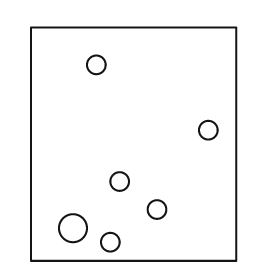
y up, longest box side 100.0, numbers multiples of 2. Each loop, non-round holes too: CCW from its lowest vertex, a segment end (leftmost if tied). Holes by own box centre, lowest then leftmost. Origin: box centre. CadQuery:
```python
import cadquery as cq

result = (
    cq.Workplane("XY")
    .moveTo(-44.0, -50.0)
    .lineTo(44.0, -50.0)
    .lineTo(44.0, 50.0)
    .lineTo(-44.0, 50.0)
    .close()
    .moveTo(-10.0, -42.0)
    .circle(4.0)
    .moveTo(-26.0, -36.0)
    .circle(6.0)
    .moveTo(10.0, -28.0)
    .circle(4.0)
    .moveTo(-6.0, -16.0)
    .circle(4.0)
    .moveTo(32.0, 6.0)
    .circle(4.0)
    .moveTo(-16.0, 34.0)
    .circle(4.0)
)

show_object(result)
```